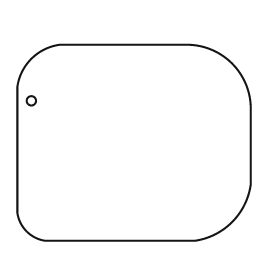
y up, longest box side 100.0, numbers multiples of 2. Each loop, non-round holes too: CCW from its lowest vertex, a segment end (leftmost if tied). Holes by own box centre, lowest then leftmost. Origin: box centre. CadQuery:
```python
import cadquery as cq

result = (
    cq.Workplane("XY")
    .moveTo(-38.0, -42.0)
    .lineTo(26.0, -42.0)
    .threePointArc((42.0, -34.0), (50.0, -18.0))
    .lineTo(50.0, 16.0)
    .threePointArc((42.0, 34.0), (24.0, 42.0))
    .lineTo(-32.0, 42.0)
    .threePointArc((-44.0, 36.0), (-50.0, 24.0))
    .lineTo(-50.0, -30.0)
    .threePointArc((-46.0, -38.0), (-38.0, -42.0))
    .close()
    .moveTo(-44.0, 18.0)
    .circle(2.0)
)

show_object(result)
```